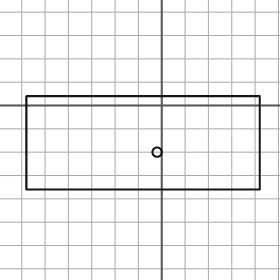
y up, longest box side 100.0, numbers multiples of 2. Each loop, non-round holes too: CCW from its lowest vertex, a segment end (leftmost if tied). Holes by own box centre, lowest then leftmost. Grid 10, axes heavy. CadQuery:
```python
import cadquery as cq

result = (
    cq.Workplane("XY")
    .moveTo(-58.0, -36.0)
    .lineTo(42.0, -36.0)
    .lineTo(42.0, 4.0)
    .lineTo(-58.0, 4.0)
    .close()
    .moveTo(-2.0, -20.0)
    .circle(2.0)
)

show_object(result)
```